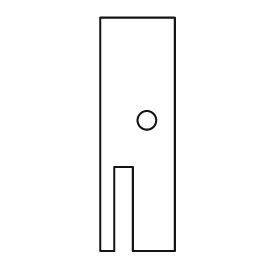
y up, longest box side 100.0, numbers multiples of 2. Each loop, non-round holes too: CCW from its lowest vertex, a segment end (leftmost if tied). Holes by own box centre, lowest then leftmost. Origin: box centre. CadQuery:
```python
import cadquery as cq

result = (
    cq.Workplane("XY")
    .moveTo(-16.0, -50.0)
    .lineTo(-10.0, -50.0)
    .lineTo(-10.0, -14.0)
    .lineTo(-2.0, -14.0)
    .lineTo(-2.0, -50.0)
    .lineTo(16.0, -50.0)
    .lineTo(16.0, 50.0)
    .lineTo(-16.0, 50.0)
    .close()
    .moveTo(4.0, 6.0)
    .circle(4.0)
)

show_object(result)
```